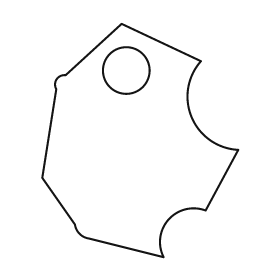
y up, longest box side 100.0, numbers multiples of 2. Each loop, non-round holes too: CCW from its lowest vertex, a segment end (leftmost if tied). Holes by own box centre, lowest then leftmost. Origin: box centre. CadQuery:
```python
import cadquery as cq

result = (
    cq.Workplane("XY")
    .moveTo(10.0, -50.0)
    .threePointArc((12.0, -34.0), (28.0, -30.0))
    .lineTo(42.0, -4.0)
    .threePointArc((22.0, 10.0), (26.0, 34.0))
    .lineTo(-8.0, 50.0)
    .lineTo(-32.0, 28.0)
    .threePointArc((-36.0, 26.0), (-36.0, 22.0))
    .lineTo(-42.0, -16.0)
    .lineTo(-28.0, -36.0)
    .threePointArc((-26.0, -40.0), (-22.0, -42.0))
    .close()
    .moveTo(-6.0, 30.0)
    .circle(10.0)
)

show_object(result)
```